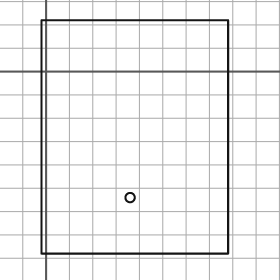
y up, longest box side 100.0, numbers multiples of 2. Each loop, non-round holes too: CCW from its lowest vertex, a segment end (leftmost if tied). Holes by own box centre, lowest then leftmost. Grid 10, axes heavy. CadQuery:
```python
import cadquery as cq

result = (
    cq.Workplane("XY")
    .moveTo(-2.0, -78.0)
    .lineTo(78.0, -78.0)
    .lineTo(78.0, 22.0)
    .lineTo(-2.0, 22.0)
    .close()
    .moveTo(36.0, -54.0)
    .circle(2.0)
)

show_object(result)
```